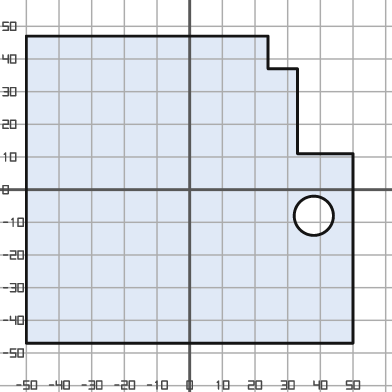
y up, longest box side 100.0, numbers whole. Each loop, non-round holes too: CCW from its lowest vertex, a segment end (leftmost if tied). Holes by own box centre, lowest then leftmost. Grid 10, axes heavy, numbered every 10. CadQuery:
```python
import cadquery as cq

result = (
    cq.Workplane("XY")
    .moveTo(-50.0, -47.0)
    .lineTo(50.0, -47.0)
    .lineTo(50.0, 11.0)
    .lineTo(33.0, 11.0)
    .lineTo(33.0, 37.0)
    .lineTo(24.0, 37.0)
    .lineTo(24.0, 47.0)
    .lineTo(-50.0, 47.0)
    .close()
    .moveTo(38.0, -8.0)
    .circle(6.0)
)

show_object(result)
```